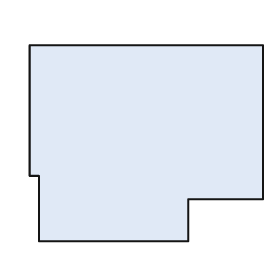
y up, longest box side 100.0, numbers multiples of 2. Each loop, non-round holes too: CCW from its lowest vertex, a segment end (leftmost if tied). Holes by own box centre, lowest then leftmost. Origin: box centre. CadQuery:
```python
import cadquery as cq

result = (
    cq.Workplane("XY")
    .moveTo(-46.0, -42.0)
    .lineTo(18.0, -42.0)
    .lineTo(18.0, -24.0)
    .lineTo(50.0, -24.0)
    .lineTo(50.0, 42.0)
    .lineTo(-50.0, 42.0)
    .lineTo(-50.0, -14.0)
    .lineTo(-46.0, -14.0)
    .close()
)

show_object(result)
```